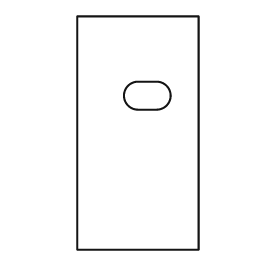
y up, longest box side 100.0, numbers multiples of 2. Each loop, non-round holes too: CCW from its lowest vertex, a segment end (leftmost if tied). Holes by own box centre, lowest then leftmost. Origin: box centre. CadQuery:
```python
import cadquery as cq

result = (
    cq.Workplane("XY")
    .moveTo(-26.0, -50.0)
    .lineTo(26.0, -50.0)
    .lineTo(26.0, 50.0)
    .lineTo(-26.0, 50.0)
    .close()
    .moveTo(0.0, 10.0)
    .lineTo(8.0, 10.0)
    .threePointArc((14.0, 16.0), (8.0, 22.0))
    .lineTo(0.0, 22.0)
    .threePointArc((-6.0, 16.0), (0.0, 10.0))
    .close()
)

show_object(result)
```